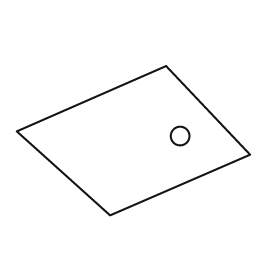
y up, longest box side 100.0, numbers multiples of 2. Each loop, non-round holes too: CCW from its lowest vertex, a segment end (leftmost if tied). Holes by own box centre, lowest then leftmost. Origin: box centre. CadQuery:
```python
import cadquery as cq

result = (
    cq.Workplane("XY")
    .moveTo(-10.0, -32.0)
    .lineTo(50.0, -6.0)
    .lineTo(14.0, 32.0)
    .lineTo(-50.0, 4.0)
    .close()
    .moveTo(20.0, 2.0)
    .circle(4.0)
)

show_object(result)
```